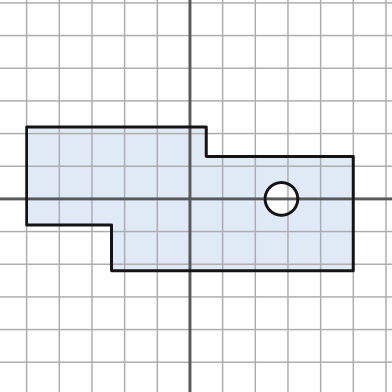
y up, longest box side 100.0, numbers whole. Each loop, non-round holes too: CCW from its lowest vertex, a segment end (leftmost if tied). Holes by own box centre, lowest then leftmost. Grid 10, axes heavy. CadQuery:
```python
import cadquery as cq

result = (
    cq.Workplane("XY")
    .moveTo(-24.0, -22.0)
    .lineTo(50.0, -22.0)
    .lineTo(50.0, 13.0)
    .lineTo(5.0, 13.0)
    .lineTo(5.0, 22.0)
    .lineTo(-50.0, 22.0)
    .lineTo(-50.0, -8.0)
    .lineTo(-24.0, -8.0)
    .close()
    .moveTo(28.0, 0.0)
    .circle(5.0)
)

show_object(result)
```